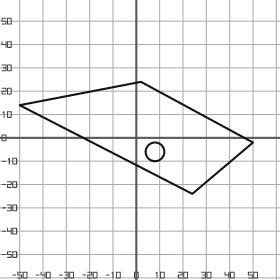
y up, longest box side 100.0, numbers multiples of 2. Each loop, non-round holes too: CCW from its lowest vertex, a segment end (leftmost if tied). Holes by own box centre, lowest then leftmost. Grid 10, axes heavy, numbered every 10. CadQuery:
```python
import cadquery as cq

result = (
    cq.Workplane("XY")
    .moveTo(24.0, -24.0)
    .lineTo(50.0, -2.0)
    .lineTo(2.0, 24.0)
    .lineTo(-50.0, 14.0)
    .close()
    .moveTo(8.0, -6.0)
    .circle(4.0)
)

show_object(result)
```